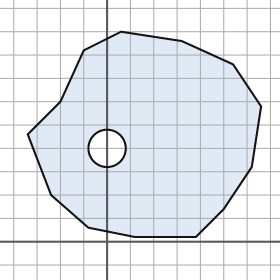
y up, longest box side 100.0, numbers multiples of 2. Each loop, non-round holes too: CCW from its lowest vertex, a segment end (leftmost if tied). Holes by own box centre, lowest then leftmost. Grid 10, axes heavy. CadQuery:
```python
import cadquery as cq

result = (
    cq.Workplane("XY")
    .moveTo(12.0, 2.0)
    .lineTo(38.0, 2.0)
    .lineTo(50.0, 14.0)
    .lineTo(62.0, 32.0)
    .lineTo(66.0, 58.0)
    .lineTo(54.0, 76.0)
    .lineTo(32.0, 86.0)
    .lineTo(6.0, 90.0)
    .lineTo(-10.0, 82.0)
    .lineTo(-20.0, 60.0)
    .lineTo(-34.0, 46.0)
    .lineTo(-24.0, 20.0)
    .lineTo(-8.0, 6.0)
    .close()
    .moveTo(0.0, 40.0)
    .circle(8.0)
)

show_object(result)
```